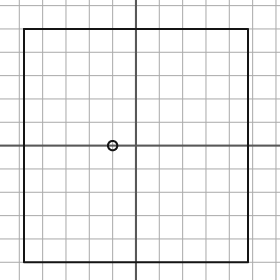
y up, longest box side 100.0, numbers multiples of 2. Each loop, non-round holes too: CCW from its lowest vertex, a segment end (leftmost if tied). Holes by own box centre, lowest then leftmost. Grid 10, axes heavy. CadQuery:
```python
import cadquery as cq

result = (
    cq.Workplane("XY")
    .moveTo(-48.0, -50.0)
    .lineTo(48.0, -50.0)
    .lineTo(48.0, 50.0)
    .lineTo(-48.0, 50.0)
    .close()
    .moveTo(-10.0, 0.0)
    .circle(2.0)
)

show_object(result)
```